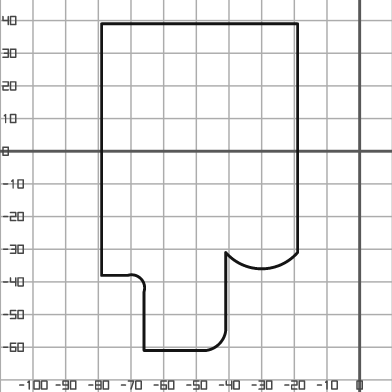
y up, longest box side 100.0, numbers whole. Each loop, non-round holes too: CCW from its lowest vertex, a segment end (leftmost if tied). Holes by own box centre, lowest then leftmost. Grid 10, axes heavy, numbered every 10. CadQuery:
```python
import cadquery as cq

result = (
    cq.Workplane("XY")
    .moveTo(-66.0, -61.0)
    .lineTo(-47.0, -61.0)
    .threePointArc((-43.0, -59.0), (-41.0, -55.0))
    .lineTo(-41.0, -31.0)
    .threePointArc((-30.0, -36.0), (-19.0, -31.0))
    .lineTo(-19.0, 39.0)
    .lineTo(-79.0, 39.0)
    .lineTo(-79.0, -38.0)
    .lineTo(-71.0, -38.0)
    .threePointArc((-67.0, -39.0), (-66.0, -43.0))
    .close()
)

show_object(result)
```